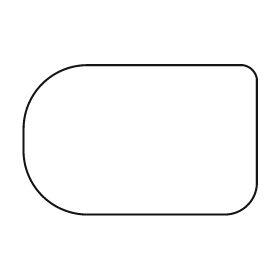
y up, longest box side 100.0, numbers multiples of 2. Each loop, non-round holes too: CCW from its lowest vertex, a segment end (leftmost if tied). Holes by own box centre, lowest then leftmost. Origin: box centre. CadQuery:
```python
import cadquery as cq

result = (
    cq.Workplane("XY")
    .moveTo(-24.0, -32.0)
    .lineTo(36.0, -32.0)
    .threePointArc((46.0, -28.0), (50.0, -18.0))
    .lineTo(50.0, 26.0)
    .threePointArc((48.0, 30.0), (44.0, 32.0))
    .lineTo(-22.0, 32.0)
    .threePointArc((-42.0, 24.0), (-50.0, 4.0))
    .lineTo(-50.0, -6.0)
    .threePointArc((-42.0, -24.0), (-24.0, -32.0))
    .close()
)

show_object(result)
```